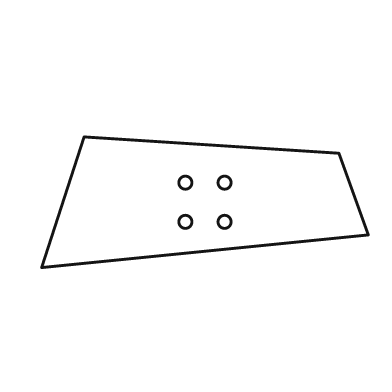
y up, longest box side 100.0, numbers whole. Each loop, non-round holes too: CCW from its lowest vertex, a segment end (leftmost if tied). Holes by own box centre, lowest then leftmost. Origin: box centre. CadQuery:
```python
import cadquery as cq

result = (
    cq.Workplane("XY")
    .moveTo(-50.0, -20.0)
    .lineTo(50.0, -10.0)
    .lineTo(41.0, 15.0)
    .lineTo(-37.0, 20.0)
    .close()
    .moveTo(-6.0, -6.0)
    .circle(2.0)
    .moveTo(6.0, -6.0)
    .circle(2.0)
    .moveTo(-6.0, 6.0)
    .circle(2.0)
    .moveTo(6.0, 6.0)
    .circle(2.0)
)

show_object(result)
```